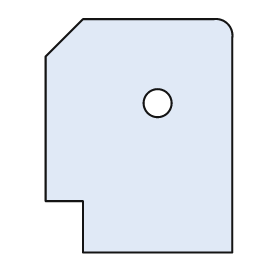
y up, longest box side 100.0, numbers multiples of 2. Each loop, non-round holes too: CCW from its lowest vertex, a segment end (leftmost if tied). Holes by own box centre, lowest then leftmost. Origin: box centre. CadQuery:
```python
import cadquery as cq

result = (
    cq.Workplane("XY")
    .moveTo(-24.0, -50.0)
    .lineTo(40.0, -50.0)
    .lineTo(40.0, 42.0)
    .threePointArc((38.0, 48.0), (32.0, 50.0))
    .lineTo(-24.0, 50.0)
    .lineTo(-40.0, 34.0)
    .lineTo(-40.0, -28.0)
    .lineTo(-24.0, -28.0)
    .close()
    .moveTo(8.0, 14.0)
    .circle(6.0)
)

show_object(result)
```